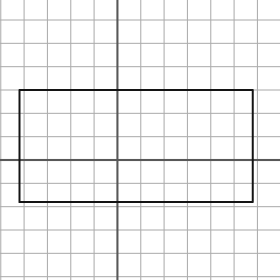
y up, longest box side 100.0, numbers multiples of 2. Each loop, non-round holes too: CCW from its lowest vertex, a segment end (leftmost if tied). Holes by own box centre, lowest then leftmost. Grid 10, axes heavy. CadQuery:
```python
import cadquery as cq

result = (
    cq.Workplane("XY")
    .moveTo(-42.0, -18.0)
    .lineTo(58.0, -18.0)
    .lineTo(58.0, 30.0)
    .lineTo(-42.0, 30.0)
    .close()
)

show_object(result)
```